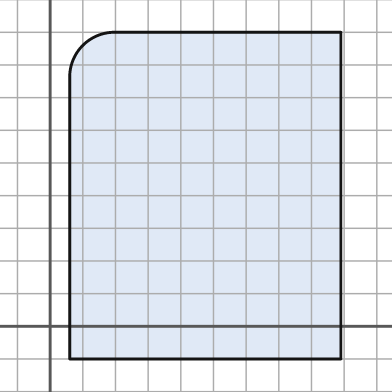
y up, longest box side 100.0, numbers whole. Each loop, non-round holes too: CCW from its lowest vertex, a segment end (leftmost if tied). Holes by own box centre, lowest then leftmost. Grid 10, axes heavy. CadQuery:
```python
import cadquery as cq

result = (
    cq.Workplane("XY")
    .moveTo(6.0, -10.0)
    .lineTo(89.0, -10.0)
    .lineTo(89.0, 90.0)
    .lineTo(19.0, 90.0)
    .threePointArc((10.0, 86.0), (6.0, 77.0))
    .close()
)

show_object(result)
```